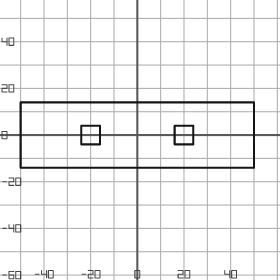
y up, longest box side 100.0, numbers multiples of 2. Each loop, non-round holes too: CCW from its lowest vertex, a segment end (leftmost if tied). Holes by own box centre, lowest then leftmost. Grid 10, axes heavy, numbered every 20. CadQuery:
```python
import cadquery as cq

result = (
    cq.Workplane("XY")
    .moveTo(-50.0, -14.0)
    .lineTo(50.0, -14.0)
    .lineTo(50.0, 14.0)
    .lineTo(-50.0, 14.0)
    .close()
    .moveTo(-24.0, -4.0)
    .lineTo(-16.0, -4.0)
    .lineTo(-16.0, 4.0)
    .lineTo(-24.0, 4.0)
    .close()
    .moveTo(16.0, -4.0)
    .lineTo(24.0, -4.0)
    .lineTo(24.0, 4.0)
    .lineTo(16.0, 4.0)
    .close()
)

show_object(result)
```